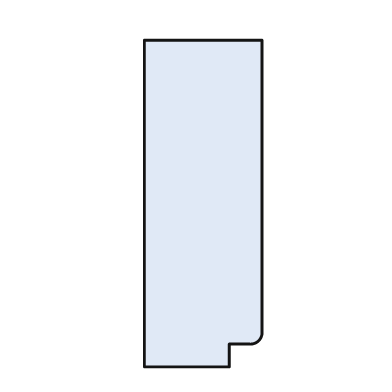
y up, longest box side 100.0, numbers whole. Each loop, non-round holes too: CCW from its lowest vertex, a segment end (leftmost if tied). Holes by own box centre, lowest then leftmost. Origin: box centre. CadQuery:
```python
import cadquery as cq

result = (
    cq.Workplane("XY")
    .moveTo(-18.0, -50.0)
    .lineTo(8.0, -50.0)
    .lineTo(8.0, -43.0)
    .lineTo(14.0, -43.0)
    .threePointArc((17.0, -42.0), (18.0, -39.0))
    .lineTo(18.0, 50.0)
    .lineTo(-18.0, 50.0)
    .close()
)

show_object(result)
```